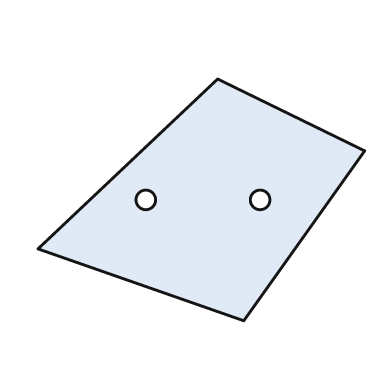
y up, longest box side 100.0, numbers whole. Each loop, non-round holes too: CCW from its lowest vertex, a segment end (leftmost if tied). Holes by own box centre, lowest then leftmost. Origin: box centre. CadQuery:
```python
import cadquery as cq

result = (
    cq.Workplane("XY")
    .moveTo(13.0, -37.0)
    .lineTo(50.0, 15.0)
    .lineTo(5.0, 37.0)
    .lineTo(-50.0, -15.0)
    .close()
    .moveTo(-17.0, 0.0)
    .circle(3.0)
    .moveTo(18.0, 0.0)
    .circle(3.0)
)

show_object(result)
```